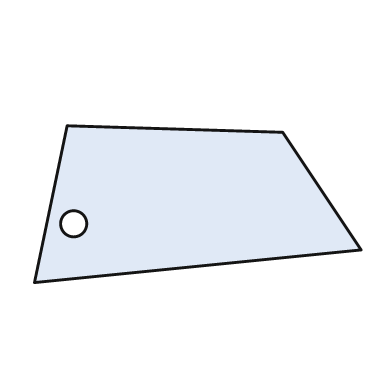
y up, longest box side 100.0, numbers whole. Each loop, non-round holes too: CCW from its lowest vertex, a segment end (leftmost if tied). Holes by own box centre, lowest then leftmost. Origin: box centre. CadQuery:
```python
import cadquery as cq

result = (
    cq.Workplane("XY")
    .moveTo(-50.0, -24.0)
    .lineTo(50.0, -14.0)
    .lineTo(26.0, 22.0)
    .lineTo(-40.0, 24.0)
    .close()
    .moveTo(-38.0, -6.0)
    .circle(4.0)
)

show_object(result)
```